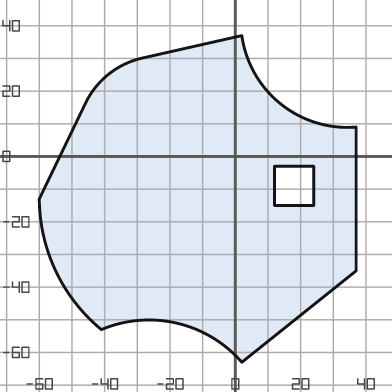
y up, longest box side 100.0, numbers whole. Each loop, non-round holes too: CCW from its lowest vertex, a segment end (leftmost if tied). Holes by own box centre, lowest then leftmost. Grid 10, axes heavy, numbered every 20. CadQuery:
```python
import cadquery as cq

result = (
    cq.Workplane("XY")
    .moveTo(2.0, -63.0)
    .lineTo(37.0, -35.0)
    .lineTo(37.0, 9.0)
    .threePointArc((14.0, 16.0), (2.0, 37.0))
    .lineTo(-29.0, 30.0)
    .threePointArc((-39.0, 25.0), (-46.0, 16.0))
    .lineTo(-60.0, -13.0)
    .threePointArc((-55.0, -35.0), (-41.0, -53.0))
    .threePointArc((-18.0, -51.0), (2.0, -63.0))
    .close()
    .moveTo(12.0, -15.0)
    .lineTo(24.0, -15.0)
    .lineTo(24.0, -3.0)
    .lineTo(12.0, -3.0)
    .close()
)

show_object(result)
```